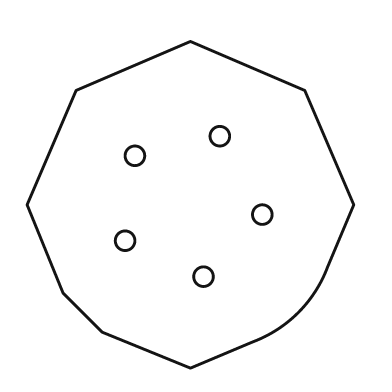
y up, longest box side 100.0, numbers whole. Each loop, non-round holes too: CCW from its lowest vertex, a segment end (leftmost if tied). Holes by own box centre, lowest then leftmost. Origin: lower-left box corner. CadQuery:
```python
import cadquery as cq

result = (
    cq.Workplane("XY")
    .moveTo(50.0, 0.0)
    .lineTo(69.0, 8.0)
    .threePointArc((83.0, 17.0), (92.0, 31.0))
    .lineTo(100.0, 50.0)
    .lineTo(85.0, 85.0)
    .lineTo(50.0, 100.0)
    .lineTo(15.0, 85.0)
    .lineTo(0.0, 50.0)
    .lineTo(11.0, 23.0)
    .lineTo(23.0, 11.0)
    .close()
    .moveTo(54.0, 28.0)
    .circle(3.0)
    .moveTo(30.0, 39.0)
    .circle(3.0)
    .moveTo(72.0, 47.0)
    .circle(3.0)
    .moveTo(33.0, 65.0)
    .circle(3.0)
    .moveTo(59.0, 71.0)
    .circle(3.0)
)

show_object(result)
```